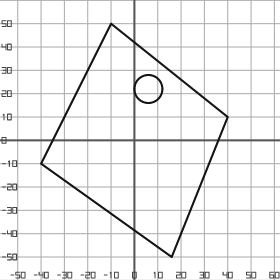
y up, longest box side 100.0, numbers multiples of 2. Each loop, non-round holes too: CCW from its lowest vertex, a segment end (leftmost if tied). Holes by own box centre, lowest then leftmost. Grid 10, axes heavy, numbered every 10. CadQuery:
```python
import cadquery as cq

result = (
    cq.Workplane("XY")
    .moveTo(16.0, -50.0)
    .lineTo(40.0, 10.0)
    .lineTo(-10.0, 50.0)
    .lineTo(-40.0, -10.0)
    .close()
    .moveTo(6.0, 22.0)
    .circle(6.0)
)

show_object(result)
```